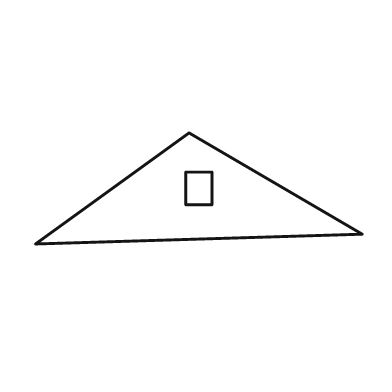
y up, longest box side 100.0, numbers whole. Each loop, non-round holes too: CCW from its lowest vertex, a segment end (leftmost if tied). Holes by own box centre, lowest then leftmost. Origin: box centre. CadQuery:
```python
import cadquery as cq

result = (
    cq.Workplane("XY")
    .moveTo(-50.0, -17.0)
    .lineTo(50.0, -14.0)
    .lineTo(-3.0, 17.0)
    .close()
    .moveTo(-4.0, -5.0)
    .lineTo(4.0, -5.0)
    .lineTo(4.0, 5.0)
    .lineTo(-4.0, 5.0)
    .close()
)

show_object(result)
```